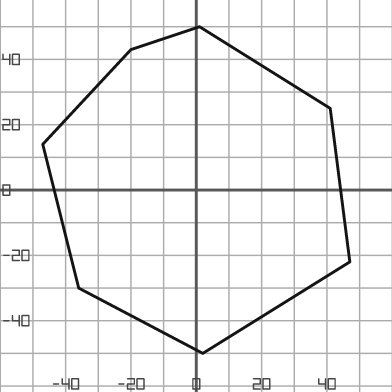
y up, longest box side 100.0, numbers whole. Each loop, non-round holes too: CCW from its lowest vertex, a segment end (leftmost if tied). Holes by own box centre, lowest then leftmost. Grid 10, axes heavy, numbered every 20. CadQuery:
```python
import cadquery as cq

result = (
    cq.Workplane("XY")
    .moveTo(2.0, -50.0)
    .lineTo(47.0, -22.0)
    .lineTo(41.0, 25.0)
    .lineTo(1.0, 50.0)
    .lineTo(-20.0, 43.0)
    .lineTo(-47.0, 14.0)
    .lineTo(-36.0, -30.0)
    .close()
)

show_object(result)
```